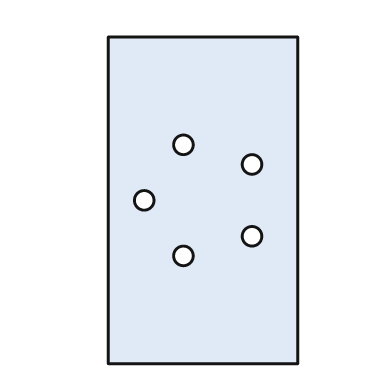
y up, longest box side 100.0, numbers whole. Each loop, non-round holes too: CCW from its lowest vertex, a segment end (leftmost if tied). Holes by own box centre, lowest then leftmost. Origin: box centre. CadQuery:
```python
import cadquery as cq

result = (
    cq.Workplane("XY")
    .moveTo(-29.0, -50.0)
    .lineTo(29.0, -50.0)
    .lineTo(29.0, 50.0)
    .lineTo(-29.0, 50.0)
    .close()
    .moveTo(-6.0, -17.0)
    .circle(3.0)
    .moveTo(15.0, -11.0)
    .circle(3.0)
    .moveTo(-18.0, 0.0)
    .circle(3.0)
    .moveTo(15.0, 11.0)
    .circle(3.0)
    .moveTo(-6.0, 17.0)
    .circle(3.0)
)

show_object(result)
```